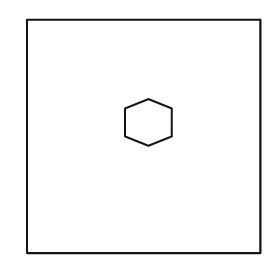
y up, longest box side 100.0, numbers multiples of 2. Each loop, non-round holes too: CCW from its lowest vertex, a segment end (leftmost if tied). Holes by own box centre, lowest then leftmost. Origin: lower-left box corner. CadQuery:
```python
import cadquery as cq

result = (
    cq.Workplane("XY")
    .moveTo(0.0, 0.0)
    .lineTo(100.0, 0.0)
    .lineTo(100.0, 100.0)
    .lineTo(0.0, 100.0)
    .close()
    .moveTo(52.0, 46.0)
    .lineTo(62.0, 50.0)
    .lineTo(62.0, 62.0)
    .lineTo(52.0, 66.0)
    .lineTo(42.0, 62.0)
    .lineTo(42.0, 50.0)
    .close()
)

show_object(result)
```